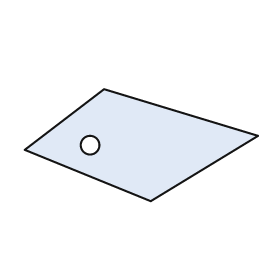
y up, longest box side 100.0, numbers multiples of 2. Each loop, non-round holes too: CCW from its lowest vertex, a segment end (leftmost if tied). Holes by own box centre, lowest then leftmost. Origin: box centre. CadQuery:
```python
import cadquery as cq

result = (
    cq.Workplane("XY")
    .moveTo(4.0, -24.0)
    .lineTo(50.0, 4.0)
    .lineTo(-16.0, 24.0)
    .lineTo(-50.0, -2.0)
    .close()
    .moveTo(-22.0, 0.0)
    .circle(4.0)
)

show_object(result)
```